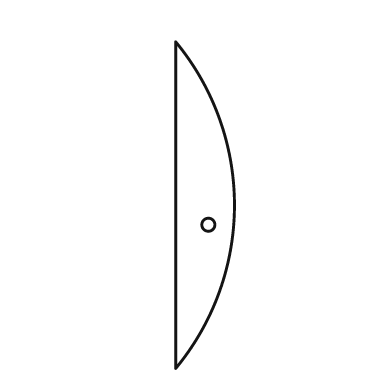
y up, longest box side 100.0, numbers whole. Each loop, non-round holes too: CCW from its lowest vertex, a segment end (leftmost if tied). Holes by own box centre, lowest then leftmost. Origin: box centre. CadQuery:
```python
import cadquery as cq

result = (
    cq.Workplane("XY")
    .moveTo(-9.0, -50.0)
    .threePointArc((9.0, 0.0), (-9.0, 50.0))
    .close()
    .moveTo(1.0, -6.0)
    .circle(2.0)
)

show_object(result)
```